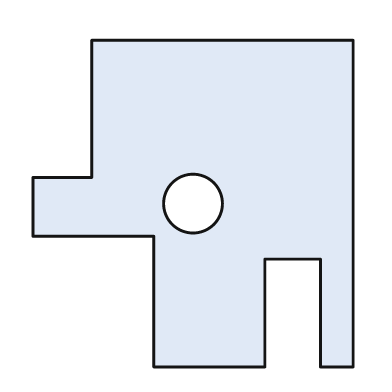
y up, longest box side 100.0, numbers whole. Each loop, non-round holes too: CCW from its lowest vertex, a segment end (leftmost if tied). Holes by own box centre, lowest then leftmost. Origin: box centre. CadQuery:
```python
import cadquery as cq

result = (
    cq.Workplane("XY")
    .moveTo(-12.0, -50.0)
    .lineTo(22.0, -50.0)
    .lineTo(22.0, -17.0)
    .lineTo(39.0, -17.0)
    .lineTo(39.0, -50.0)
    .lineTo(49.0, -50.0)
    .lineTo(49.0, 50.0)
    .lineTo(-31.0, 50.0)
    .lineTo(-31.0, 8.0)
    .lineTo(-49.0, 8.0)
    .lineTo(-49.0, -10.0)
    .lineTo(-12.0, -10.0)
    .close()
    .moveTo(0.0, 0.0)
    .circle(9.0)
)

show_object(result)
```